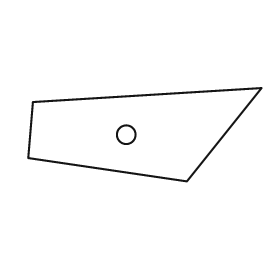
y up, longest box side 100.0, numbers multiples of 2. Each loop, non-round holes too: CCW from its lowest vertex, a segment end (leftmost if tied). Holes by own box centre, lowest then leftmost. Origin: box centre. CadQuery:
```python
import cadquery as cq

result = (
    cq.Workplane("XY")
    .moveTo(18.0, -20.0)
    .lineTo(50.0, 20.0)
    .lineTo(-48.0, 14.0)
    .lineTo(-50.0, -10.0)
    .close()
    .moveTo(-8.0, 0.0)
    .circle(4.0)
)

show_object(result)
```